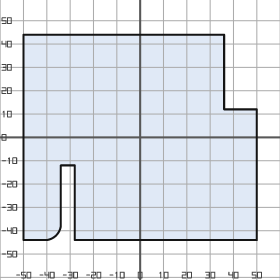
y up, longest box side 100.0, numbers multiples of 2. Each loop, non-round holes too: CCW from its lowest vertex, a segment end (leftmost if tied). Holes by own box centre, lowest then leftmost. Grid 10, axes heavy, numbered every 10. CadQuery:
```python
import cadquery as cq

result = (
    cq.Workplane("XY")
    .moveTo(-50.0, -44.0)
    .lineTo(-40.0, -44.0)
    .threePointArc((-36.0, -42.0), (-34.0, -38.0))
    .lineTo(-34.0, -12.0)
    .lineTo(-28.0, -12.0)
    .lineTo(-28.0, -44.0)
    .lineTo(50.0, -44.0)
    .lineTo(50.0, 12.0)
    .lineTo(36.0, 12.0)
    .lineTo(36.0, 44.0)
    .lineTo(-50.0, 44.0)
    .close()
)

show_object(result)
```